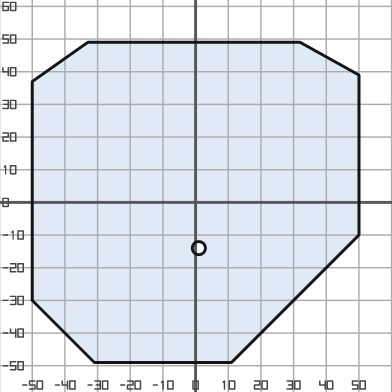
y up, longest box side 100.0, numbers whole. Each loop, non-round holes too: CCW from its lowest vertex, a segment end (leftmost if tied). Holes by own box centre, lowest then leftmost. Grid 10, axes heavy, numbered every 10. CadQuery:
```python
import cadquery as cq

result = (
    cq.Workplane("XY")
    .moveTo(-31.0, -49.0)
    .lineTo(11.0, -49.0)
    .lineTo(50.0, -10.0)
    .lineTo(50.0, 39.0)
    .lineTo(32.0, 49.0)
    .lineTo(-33.0, 49.0)
    .lineTo(-50.0, 37.0)
    .lineTo(-50.0, -30.0)
    .close()
    .moveTo(1.0, -14.0)
    .circle(2.0)
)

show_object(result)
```